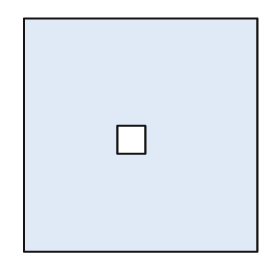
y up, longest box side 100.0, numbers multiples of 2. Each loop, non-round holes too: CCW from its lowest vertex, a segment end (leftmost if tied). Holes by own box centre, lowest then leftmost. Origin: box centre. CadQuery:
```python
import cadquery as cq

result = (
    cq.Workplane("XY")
    .moveTo(-50.0, -50.0)
    .lineTo(50.0, -50.0)
    .lineTo(50.0, 50.0)
    .lineTo(-50.0, 50.0)
    .close()
    .moveTo(-10.0, -8.0)
    .lineTo(2.0, -8.0)
    .lineTo(2.0, 4.0)
    .lineTo(-10.0, 4.0)
    .close()
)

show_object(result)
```